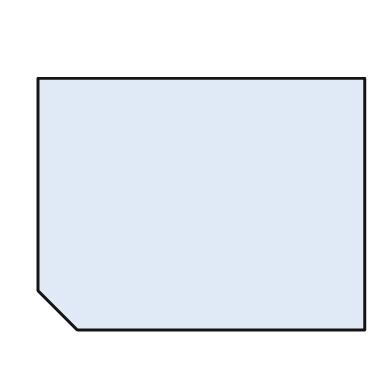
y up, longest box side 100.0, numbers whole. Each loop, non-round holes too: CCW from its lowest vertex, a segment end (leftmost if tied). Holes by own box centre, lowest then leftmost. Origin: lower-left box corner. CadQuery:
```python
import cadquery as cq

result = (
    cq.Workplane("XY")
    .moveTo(12.0, 0.0)
    .lineTo(100.0, 0.0)
    .lineTo(100.0, 77.0)
    .lineTo(0.0, 77.0)
    .lineTo(0.0, 12.0)
    .close()
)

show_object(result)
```